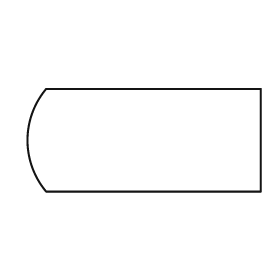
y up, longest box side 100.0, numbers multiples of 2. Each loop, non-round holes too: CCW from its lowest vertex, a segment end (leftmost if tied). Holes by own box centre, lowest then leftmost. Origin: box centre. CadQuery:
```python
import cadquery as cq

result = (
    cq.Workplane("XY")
    .moveTo(-42.0, -22.0)
    .lineTo(50.0, -22.0)
    .lineTo(50.0, 22.0)
    .lineTo(-42.0, 22.0)
    .threePointArc((-50.0, 0.0), (-42.0, -22.0))
    .close()
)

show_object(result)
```